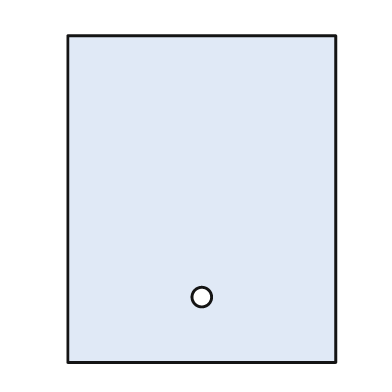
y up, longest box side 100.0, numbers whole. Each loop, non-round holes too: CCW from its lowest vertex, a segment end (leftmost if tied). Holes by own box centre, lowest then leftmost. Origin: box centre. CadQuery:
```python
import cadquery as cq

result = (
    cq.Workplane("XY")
    .moveTo(-41.0, -50.0)
    .lineTo(41.0, -50.0)
    .lineTo(41.0, 50.0)
    .lineTo(-41.0, 50.0)
    .close()
    .moveTo(0.0, -30.0)
    .circle(3.0)
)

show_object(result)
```